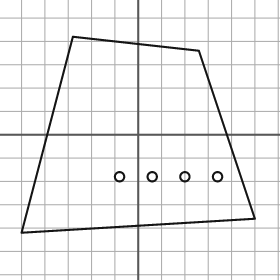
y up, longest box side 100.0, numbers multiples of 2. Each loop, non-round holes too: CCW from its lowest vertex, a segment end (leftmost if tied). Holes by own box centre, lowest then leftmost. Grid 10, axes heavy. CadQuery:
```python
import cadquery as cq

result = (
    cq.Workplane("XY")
    .moveTo(-50.0, -42.0)
    .lineTo(50.0, -36.0)
    .lineTo(26.0, 36.0)
    .lineTo(-28.0, 42.0)
    .close()
    .moveTo(-8.0, -18.0)
    .circle(2.0)
    .moveTo(6.0, -18.0)
    .circle(2.0)
    .moveTo(20.0, -18.0)
    .circle(2.0)
    .moveTo(34.0, -18.0)
    .circle(2.0)
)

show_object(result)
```